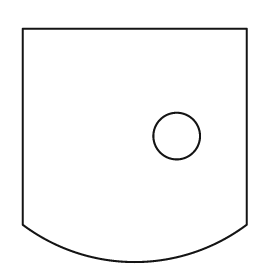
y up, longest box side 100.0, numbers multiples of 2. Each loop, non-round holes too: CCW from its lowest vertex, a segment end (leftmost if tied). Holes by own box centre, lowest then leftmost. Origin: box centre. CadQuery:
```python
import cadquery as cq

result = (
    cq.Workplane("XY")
    .moveTo(-48.0, -34.0)
    .threePointArc((0.0, -50.0), (48.0, -34.0))
    .lineTo(48.0, 50.0)
    .lineTo(-48.0, 50.0)
    .close()
    .moveTo(18.0, 4.0)
    .circle(10.0)
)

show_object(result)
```